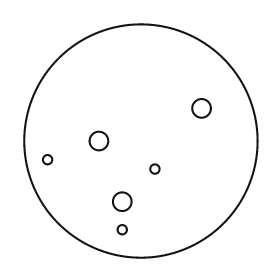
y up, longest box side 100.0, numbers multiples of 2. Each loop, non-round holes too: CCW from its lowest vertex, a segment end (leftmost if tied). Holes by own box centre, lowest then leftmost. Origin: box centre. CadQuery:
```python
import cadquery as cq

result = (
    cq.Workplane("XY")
    .moveTo(0.0, 0.0)
    .circle(50.0)
    .moveTo(-8.0, -38.0)
    .circle(2.0)
    .moveTo(-8.0, -26.0)
    .circle(4.0)
    .moveTo(6.0, -12.0)
    .circle(2.0)
    .moveTo(-40.0, -8.0)
    .circle(2.0)
    .moveTo(-18.0, 0.0)
    .circle(4.0)
    .moveTo(26.0, 14.0)
    .circle(4.0)
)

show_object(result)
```